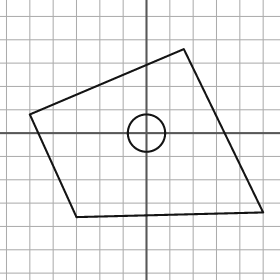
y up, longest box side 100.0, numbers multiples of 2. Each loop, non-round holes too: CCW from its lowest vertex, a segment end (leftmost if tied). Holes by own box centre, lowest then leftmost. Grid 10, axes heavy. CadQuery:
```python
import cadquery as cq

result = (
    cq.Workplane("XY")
    .moveTo(-30.0, -36.0)
    .lineTo(50.0, -34.0)
    .lineTo(16.0, 36.0)
    .lineTo(-50.0, 8.0)
    .close()
    .moveTo(0.0, 0.0)
    .circle(8.0)
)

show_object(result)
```